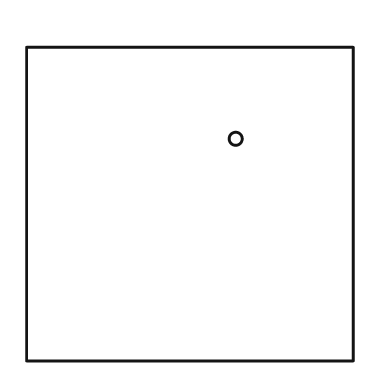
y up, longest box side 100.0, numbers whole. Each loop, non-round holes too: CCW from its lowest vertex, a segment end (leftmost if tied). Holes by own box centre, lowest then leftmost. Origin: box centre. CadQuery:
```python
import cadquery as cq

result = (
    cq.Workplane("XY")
    .moveTo(-50.0, -48.0)
    .lineTo(50.0, -48.0)
    .lineTo(50.0, 48.0)
    .lineTo(-50.0, 48.0)
    .close()
    .moveTo(14.0, 20.0)
    .circle(2.0)
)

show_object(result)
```